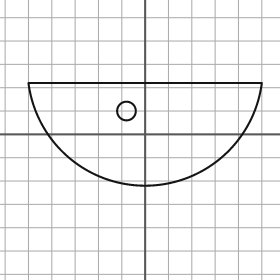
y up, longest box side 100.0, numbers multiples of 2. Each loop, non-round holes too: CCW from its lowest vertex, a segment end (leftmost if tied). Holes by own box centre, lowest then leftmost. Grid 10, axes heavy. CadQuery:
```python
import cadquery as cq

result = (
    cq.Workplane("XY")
    .moveTo(-50.0, 22.0)
    .threePointArc((0.0, -22.0), (50.0, 22.0))
    .close()
    .moveTo(-8.0, 10.0)
    .circle(4.0)
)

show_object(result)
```